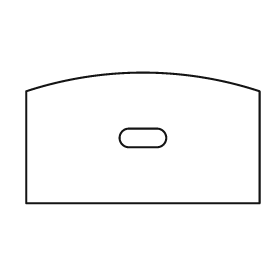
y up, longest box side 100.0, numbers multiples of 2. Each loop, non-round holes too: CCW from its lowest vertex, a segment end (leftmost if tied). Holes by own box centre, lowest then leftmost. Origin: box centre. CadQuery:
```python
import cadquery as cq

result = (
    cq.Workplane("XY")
    .moveTo(-50.0, -28.0)
    .lineTo(50.0, -28.0)
    .lineTo(50.0, 20.0)
    .threePointArc((0.0, 28.0), (-50.0, 20.0))
    .close()
    .moveTo(-6.0, -4.0)
    .lineTo(6.0, -4.0)
    .threePointArc((10.0, 0.0), (6.0, 4.0))
    .lineTo(-6.0, 4.0)
    .threePointArc((-10.0, 0.0), (-6.0, -4.0))
    .close()
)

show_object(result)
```